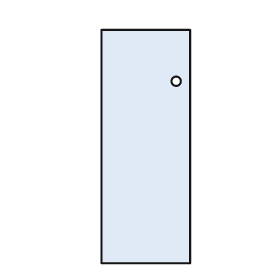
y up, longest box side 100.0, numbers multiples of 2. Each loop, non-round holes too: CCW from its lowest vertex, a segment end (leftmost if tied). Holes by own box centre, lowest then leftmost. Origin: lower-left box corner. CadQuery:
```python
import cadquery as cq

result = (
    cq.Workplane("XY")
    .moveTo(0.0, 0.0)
    .lineTo(38.0, 0.0)
    .lineTo(38.0, 100.0)
    .lineTo(0.0, 100.0)
    .close()
    .moveTo(32.0, 78.0)
    .circle(2.0)
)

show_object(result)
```